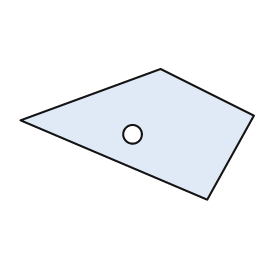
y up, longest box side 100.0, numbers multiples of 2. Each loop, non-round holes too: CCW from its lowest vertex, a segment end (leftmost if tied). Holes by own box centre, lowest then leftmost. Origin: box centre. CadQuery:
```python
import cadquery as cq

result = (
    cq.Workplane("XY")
    .moveTo(30.0, -28.0)
    .lineTo(50.0, 8.0)
    .lineTo(10.0, 28.0)
    .lineTo(-50.0, 6.0)
    .close()
    .moveTo(-2.0, 0.0)
    .circle(4.0)
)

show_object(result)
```